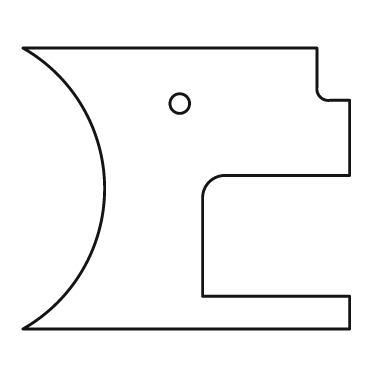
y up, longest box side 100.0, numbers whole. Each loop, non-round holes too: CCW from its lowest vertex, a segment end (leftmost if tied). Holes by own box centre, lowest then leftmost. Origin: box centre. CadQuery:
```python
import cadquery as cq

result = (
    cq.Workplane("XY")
    .moveTo(-50.0, -43.0)
    .lineTo(50.0, -43.0)
    .lineTo(50.0, -33.0)
    .lineTo(5.0, -33.0)
    .lineTo(5.0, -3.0)
    .threePointArc((7.0, 2.0), (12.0, 4.0))
    .lineTo(50.0, 4.0)
    .lineTo(50.0, 27.0)
    .lineTo(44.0, 27.0)
    .threePointArc((41.0, 28.0), (40.0, 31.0))
    .lineTo(40.0, 43.0)
    .lineTo(-50.0, 43.0)
    .threePointArc((-25.0, 0.0), (-50.0, -43.0))
    .close()
    .moveTo(-2.0, 26.0)
    .circle(3.0)
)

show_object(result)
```